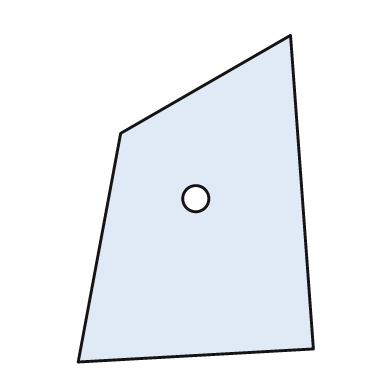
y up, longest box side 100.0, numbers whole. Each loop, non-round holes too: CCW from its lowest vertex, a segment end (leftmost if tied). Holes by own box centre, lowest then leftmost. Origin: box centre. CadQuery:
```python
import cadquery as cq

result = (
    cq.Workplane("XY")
    .moveTo(-36.0, -50.0)
    .lineTo(36.0, -46.0)
    .lineTo(29.0, 50.0)
    .lineTo(-23.0, 20.0)
    .close()
    .moveTo(0.0, 0.0)
    .circle(4.0)
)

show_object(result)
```